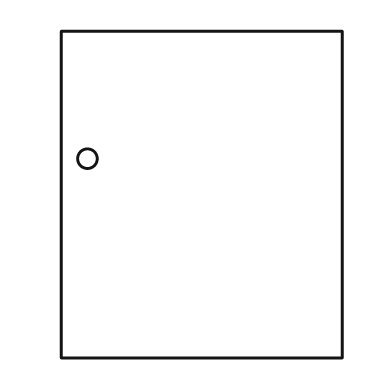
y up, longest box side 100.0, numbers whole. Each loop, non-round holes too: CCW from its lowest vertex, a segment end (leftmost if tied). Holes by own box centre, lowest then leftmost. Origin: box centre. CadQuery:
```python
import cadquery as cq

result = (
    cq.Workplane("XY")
    .moveTo(-43.0, -50.0)
    .lineTo(43.0, -50.0)
    .lineTo(43.0, 50.0)
    .lineTo(-43.0, 50.0)
    .close()
    .moveTo(-35.0, 11.0)
    .circle(3.0)
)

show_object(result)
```